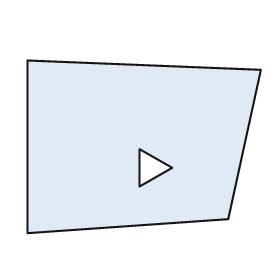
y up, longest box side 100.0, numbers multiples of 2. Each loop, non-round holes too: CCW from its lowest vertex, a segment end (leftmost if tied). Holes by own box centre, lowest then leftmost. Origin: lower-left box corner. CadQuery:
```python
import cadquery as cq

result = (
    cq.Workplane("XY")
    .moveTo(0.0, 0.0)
    .lineTo(86.0, 6.0)
    .lineTo(100.0, 70.0)
    .lineTo(0.0, 74.0)
    .close()
    .moveTo(48.0, 20.0)
    .lineTo(62.0, 28.0)
    .lineTo(48.0, 36.0)
    .close()
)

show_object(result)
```